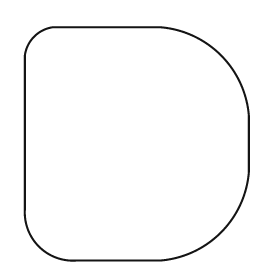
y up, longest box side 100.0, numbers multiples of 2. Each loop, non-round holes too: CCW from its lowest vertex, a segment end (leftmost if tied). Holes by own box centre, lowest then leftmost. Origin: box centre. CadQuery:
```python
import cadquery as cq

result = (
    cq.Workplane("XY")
    .moveTo(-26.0, -50.0)
    .lineTo(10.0, -50.0)
    .threePointArc((36.0, -38.0), (48.0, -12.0))
    .lineTo(48.0, 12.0)
    .threePointArc((36.0, 38.0), (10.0, 50.0))
    .lineTo(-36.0, 50.0)
    .threePointArc((-44.0, 46.0), (-48.0, 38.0))
    .lineTo(-48.0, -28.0)
    .threePointArc((-42.0, -44.0), (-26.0, -50.0))
    .close()
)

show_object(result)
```